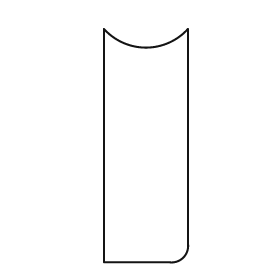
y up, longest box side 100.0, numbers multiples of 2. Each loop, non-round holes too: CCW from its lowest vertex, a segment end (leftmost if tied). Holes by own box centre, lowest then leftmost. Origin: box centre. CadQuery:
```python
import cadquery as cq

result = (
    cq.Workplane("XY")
    .moveTo(-18.0, -50.0)
    .lineTo(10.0, -50.0)
    .threePointArc((16.0, -48.0), (18.0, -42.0))
    .lineTo(18.0, 50.0)
    .threePointArc((0.0, 42.0), (-18.0, 50.0))
    .close()
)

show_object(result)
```